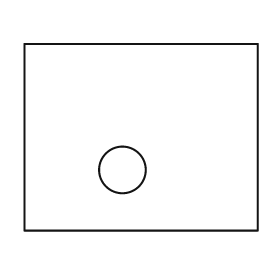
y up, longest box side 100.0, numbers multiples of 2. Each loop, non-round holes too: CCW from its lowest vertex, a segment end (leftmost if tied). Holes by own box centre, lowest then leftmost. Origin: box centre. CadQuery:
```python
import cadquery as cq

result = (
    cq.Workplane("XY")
    .moveTo(-50.0, -40.0)
    .lineTo(50.0, -40.0)
    .lineTo(50.0, 40.0)
    .lineTo(-50.0, 40.0)
    .close()
    .moveTo(-8.0, -14.0)
    .circle(10.0)
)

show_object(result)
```